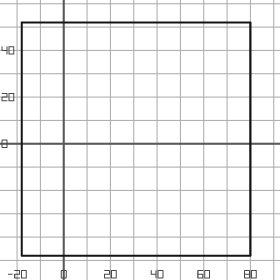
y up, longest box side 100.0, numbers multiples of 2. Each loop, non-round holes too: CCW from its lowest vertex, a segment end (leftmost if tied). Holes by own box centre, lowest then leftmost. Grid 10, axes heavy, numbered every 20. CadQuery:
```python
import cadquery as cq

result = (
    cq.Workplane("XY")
    .moveTo(-18.0, -48.0)
    .lineTo(80.0, -48.0)
    .lineTo(80.0, 52.0)
    .lineTo(-18.0, 52.0)
    .close()
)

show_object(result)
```